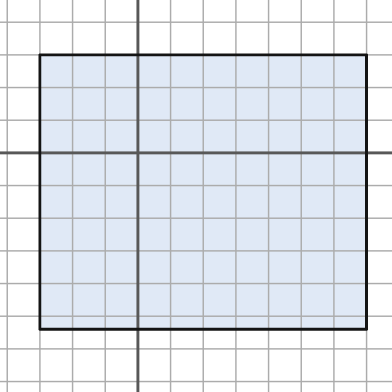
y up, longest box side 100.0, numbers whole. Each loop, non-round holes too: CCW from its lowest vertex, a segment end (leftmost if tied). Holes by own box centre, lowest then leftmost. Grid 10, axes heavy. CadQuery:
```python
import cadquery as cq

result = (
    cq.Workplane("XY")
    .moveTo(-30.0, -54.0)
    .lineTo(70.0, -54.0)
    .lineTo(70.0, 30.0)
    .lineTo(-30.0, 30.0)
    .close()
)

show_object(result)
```